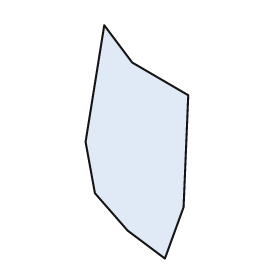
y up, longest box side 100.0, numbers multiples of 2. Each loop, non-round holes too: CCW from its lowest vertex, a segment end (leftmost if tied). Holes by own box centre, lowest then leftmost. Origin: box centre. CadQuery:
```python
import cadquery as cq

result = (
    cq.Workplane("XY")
    .moveTo(12.0, -50.0)
    .lineTo(20.0, -28.0)
    .lineTo(22.0, 20.0)
    .lineTo(-2.0, 34.0)
    .lineTo(-14.0, 50.0)
    .lineTo(-22.0, 0.0)
    .lineTo(-18.0, -22.0)
    .lineTo(-4.0, -38.0)
    .close()
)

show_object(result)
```